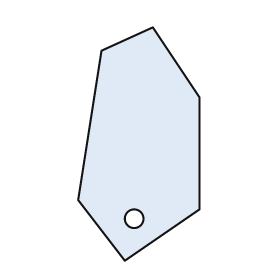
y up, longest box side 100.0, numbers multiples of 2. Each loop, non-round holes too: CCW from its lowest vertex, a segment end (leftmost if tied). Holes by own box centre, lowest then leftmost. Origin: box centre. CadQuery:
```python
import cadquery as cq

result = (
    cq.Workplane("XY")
    .moveTo(-6.0, -50.0)
    .lineTo(26.0, -28.0)
    .lineTo(26.0, 20.0)
    .lineTo(6.0, 50.0)
    .lineTo(-16.0, 40.0)
    .lineTo(-26.0, -24.0)
    .close()
    .moveTo(-2.0, -32.0)
    .circle(4.0)
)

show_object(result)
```